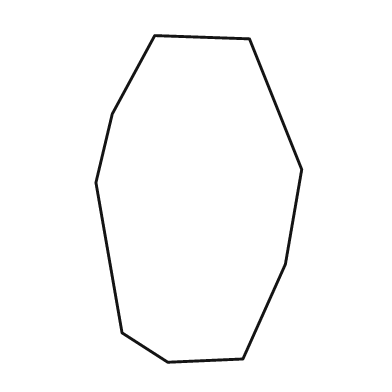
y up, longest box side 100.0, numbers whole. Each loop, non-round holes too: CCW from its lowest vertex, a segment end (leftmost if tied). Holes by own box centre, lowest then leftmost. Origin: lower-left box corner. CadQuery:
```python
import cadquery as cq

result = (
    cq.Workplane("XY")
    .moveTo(22.0, 0.0)
    .lineTo(45.0, 1.0)
    .lineTo(58.0, 30.0)
    .lineTo(63.0, 59.0)
    .lineTo(47.0, 99.0)
    .lineTo(18.0, 100.0)
    .lineTo(5.0, 76.0)
    .lineTo(0.0, 55.0)
    .lineTo(8.0, 9.0)
    .close()
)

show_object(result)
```